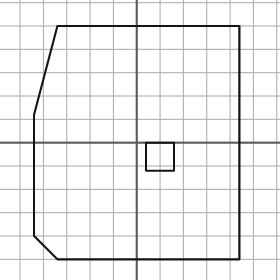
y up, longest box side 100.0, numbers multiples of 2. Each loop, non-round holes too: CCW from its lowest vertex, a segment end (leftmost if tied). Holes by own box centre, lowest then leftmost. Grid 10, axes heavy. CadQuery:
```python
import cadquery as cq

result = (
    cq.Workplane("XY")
    .moveTo(-34.0, -50.0)
    .lineTo(44.0, -50.0)
    .lineTo(44.0, 50.0)
    .lineTo(-34.0, 50.0)
    .lineTo(-44.0, 12.0)
    .lineTo(-44.0, -40.0)
    .close()
    .moveTo(4.0, -12.0)
    .lineTo(16.0, -12.0)
    .lineTo(16.0, 0.0)
    .lineTo(4.0, 0.0)
    .close()
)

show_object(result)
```